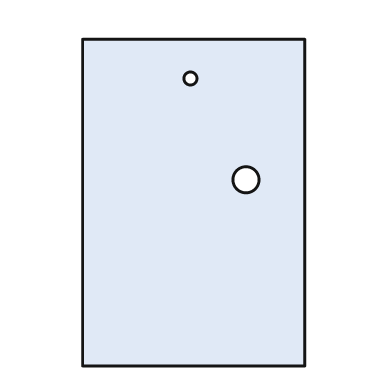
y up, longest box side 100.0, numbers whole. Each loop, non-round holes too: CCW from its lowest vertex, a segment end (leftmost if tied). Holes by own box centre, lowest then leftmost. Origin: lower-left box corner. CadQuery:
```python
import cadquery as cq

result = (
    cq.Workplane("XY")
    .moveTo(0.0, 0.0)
    .lineTo(68.0, 0.0)
    .lineTo(68.0, 100.0)
    .lineTo(0.0, 100.0)
    .close()
    .moveTo(50.0, 57.0)
    .circle(4.0)
    .moveTo(33.0, 88.0)
    .circle(2.0)
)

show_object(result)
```